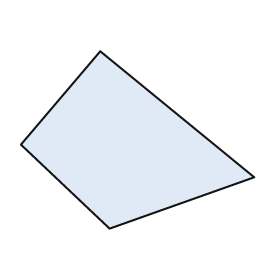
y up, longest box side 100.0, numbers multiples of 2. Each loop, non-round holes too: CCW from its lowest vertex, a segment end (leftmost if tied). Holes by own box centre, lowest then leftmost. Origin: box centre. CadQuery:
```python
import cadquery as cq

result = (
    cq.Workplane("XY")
    .moveTo(-12.0, -38.0)
    .lineTo(50.0, -16.0)
    .lineTo(-16.0, 38.0)
    .lineTo(-50.0, -2.0)
    .close()
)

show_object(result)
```